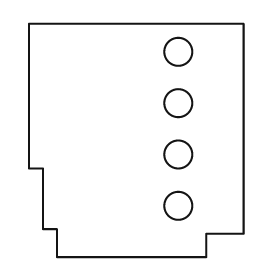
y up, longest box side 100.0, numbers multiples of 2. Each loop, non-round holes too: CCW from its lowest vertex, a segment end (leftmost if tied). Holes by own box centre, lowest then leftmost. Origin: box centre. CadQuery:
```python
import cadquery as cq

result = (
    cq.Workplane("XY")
    .moveTo(-34.0, -50.0)
    .lineTo(30.0, -50.0)
    .lineTo(30.0, -40.0)
    .lineTo(46.0, -40.0)
    .lineTo(46.0, 50.0)
    .lineTo(-46.0, 50.0)
    .lineTo(-46.0, -12.0)
    .lineTo(-40.0, -12.0)
    .lineTo(-40.0, -38.0)
    .lineTo(-34.0, -38.0)
    .close()
    .moveTo(18.0, -28.0)
    .circle(6.0)
    .moveTo(18.0, -6.0)
    .circle(6.0)
    .moveTo(18.0, 16.0)
    .circle(6.0)
    .moveTo(18.0, 38.0)
    .circle(6.0)
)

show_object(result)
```